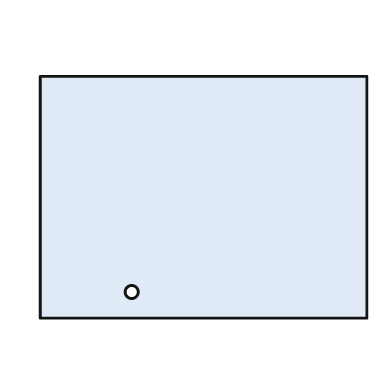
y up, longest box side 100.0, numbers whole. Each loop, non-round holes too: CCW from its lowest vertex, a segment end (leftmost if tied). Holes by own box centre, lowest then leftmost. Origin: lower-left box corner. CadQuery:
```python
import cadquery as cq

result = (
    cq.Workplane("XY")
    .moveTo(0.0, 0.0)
    .lineTo(100.0, 0.0)
    .lineTo(100.0, 74.0)
    .lineTo(0.0, 74.0)
    .close()
    .moveTo(28.0, 8.0)
    .circle(2.0)
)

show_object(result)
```